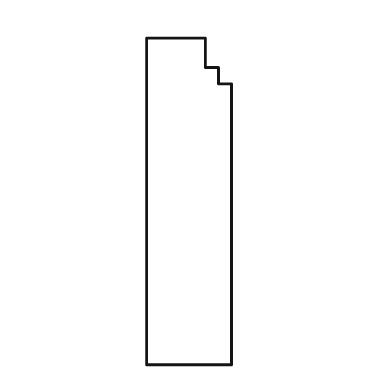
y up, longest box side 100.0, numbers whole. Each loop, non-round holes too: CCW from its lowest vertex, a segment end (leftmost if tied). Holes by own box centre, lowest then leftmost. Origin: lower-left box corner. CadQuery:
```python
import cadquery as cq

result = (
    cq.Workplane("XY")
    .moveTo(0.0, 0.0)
    .lineTo(26.0, 0.0)
    .lineTo(26.0, 86.0)
    .lineTo(22.0, 86.0)
    .lineTo(22.0, 91.0)
    .lineTo(18.0, 91.0)
    .lineTo(18.0, 100.0)
    .lineTo(0.0, 100.0)
    .close()
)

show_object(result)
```